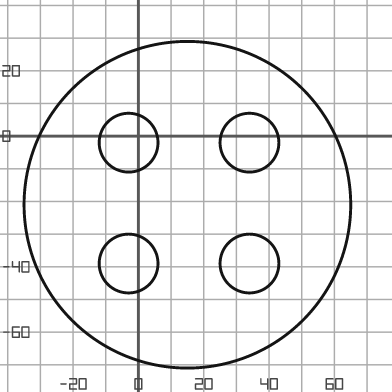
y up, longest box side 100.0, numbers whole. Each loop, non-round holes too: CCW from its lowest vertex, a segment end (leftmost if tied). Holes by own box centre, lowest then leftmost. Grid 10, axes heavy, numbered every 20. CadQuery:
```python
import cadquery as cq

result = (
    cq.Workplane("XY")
    .moveTo(15.0, -21.0)
    .circle(50.0)
    .moveTo(-3.0, -39.0)
    .circle(9.0)
    .moveTo(34.0, -39.0)
    .circle(9.0)
    .moveTo(-3.0, -2.0)
    .circle(9.0)
    .moveTo(34.0, -2.0)
    .circle(9.0)
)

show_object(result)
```